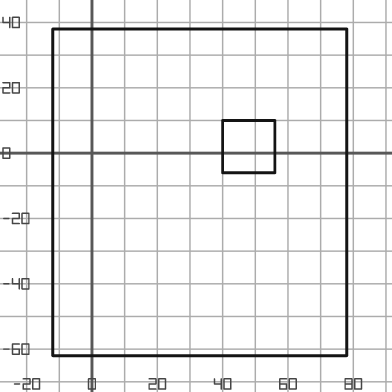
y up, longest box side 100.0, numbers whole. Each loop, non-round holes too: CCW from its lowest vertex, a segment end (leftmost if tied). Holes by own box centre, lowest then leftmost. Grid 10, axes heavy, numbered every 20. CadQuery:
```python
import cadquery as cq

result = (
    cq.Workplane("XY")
    .moveTo(-12.0, -62.0)
    .lineTo(78.0, -62.0)
    .lineTo(78.0, 38.0)
    .lineTo(-12.0, 38.0)
    .close()
    .moveTo(40.0, -6.0)
    .lineTo(56.0, -6.0)
    .lineTo(56.0, 10.0)
    .lineTo(40.0, 10.0)
    .close()
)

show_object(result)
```